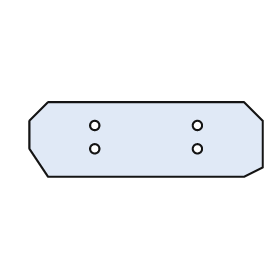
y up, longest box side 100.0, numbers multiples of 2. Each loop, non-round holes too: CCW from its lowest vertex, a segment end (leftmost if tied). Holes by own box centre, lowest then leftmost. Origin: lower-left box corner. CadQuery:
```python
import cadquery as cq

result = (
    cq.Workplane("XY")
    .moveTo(8.0, 0.0)
    .lineTo(92.0, 0.0)
    .lineTo(100.0, 4.0)
    .lineTo(100.0, 24.0)
    .lineTo(92.0, 32.0)
    .lineTo(8.0, 32.0)
    .lineTo(0.0, 24.0)
    .lineTo(0.0, 12.0)
    .close()
    .moveTo(28.0, 12.0)
    .circle(2.0)
    .moveTo(72.0, 12.0)
    .circle(2.0)
    .moveTo(28.0, 22.0)
    .circle(2.0)
    .moveTo(72.0, 22.0)
    .circle(2.0)
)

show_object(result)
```